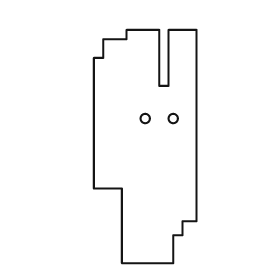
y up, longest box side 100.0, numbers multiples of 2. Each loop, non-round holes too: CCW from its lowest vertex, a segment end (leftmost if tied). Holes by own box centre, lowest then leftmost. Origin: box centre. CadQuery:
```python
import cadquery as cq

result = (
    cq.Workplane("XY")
    .moveTo(-10.0, -50.0)
    .lineTo(12.0, -50.0)
    .lineTo(12.0, -38.0)
    .lineTo(16.0, -38.0)
    .lineTo(16.0, -32.0)
    .lineTo(22.0, -32.0)
    .lineTo(22.0, 50.0)
    .lineTo(10.0, 50.0)
    .lineTo(10.0, 26.0)
    .lineTo(6.0, 26.0)
    .lineTo(6.0, 50.0)
    .lineTo(-8.0, 50.0)
    .lineTo(-8.0, 46.0)
    .lineTo(-18.0, 46.0)
    .lineTo(-18.0, 38.0)
    .lineTo(-22.0, 38.0)
    .lineTo(-22.0, -18.0)
    .lineTo(-10.0, -18.0)
    .close()
    .moveTo(0.0, 12.0)
    .circle(2.0)
    .moveTo(12.0, 12.0)
    .circle(2.0)
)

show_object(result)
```